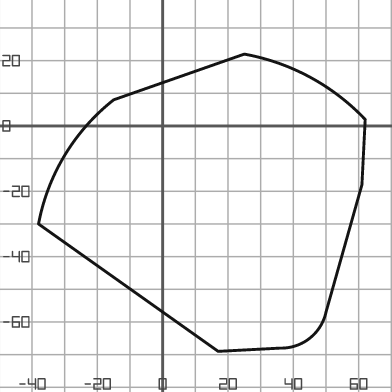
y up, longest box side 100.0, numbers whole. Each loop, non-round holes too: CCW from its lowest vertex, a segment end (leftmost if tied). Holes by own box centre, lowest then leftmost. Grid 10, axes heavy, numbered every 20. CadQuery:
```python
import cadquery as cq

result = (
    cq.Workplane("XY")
    .moveTo(17.0, -69.0)
    .lineTo(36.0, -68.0)
    .threePointArc((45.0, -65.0), (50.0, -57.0))
    .lineTo(61.0, -18.0)
    .lineTo(62.0, 2.0)
    .threePointArc((45.0, 15.0), (25.0, 22.0))
    .lineTo(-15.0, 8.0)
    .threePointArc((-30.0, -9.0), (-38.0, -30.0))
    .close()
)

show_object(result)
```